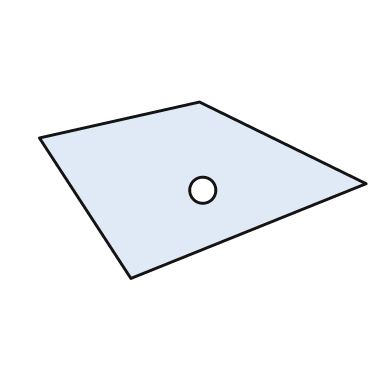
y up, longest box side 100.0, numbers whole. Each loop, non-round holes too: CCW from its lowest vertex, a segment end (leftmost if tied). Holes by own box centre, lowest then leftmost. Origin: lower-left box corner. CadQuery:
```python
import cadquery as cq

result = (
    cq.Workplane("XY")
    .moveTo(28.0, 0.0)
    .lineTo(100.0, 29.0)
    .lineTo(49.0, 54.0)
    .lineTo(0.0, 43.0)
    .close()
    .moveTo(50.0, 27.0)
    .circle(4.0)
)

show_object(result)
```